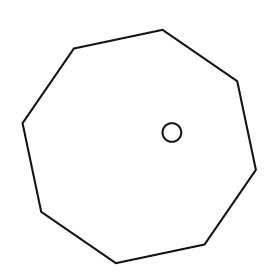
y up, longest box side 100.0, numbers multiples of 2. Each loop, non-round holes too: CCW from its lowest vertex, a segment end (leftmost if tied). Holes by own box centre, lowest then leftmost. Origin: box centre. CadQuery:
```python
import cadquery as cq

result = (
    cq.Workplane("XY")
    .moveTo(-10.0, -50.0)
    .lineTo(28.0, -42.0)
    .lineTo(50.0, -10.0)
    .lineTo(42.0, 28.0)
    .lineTo(10.0, 50.0)
    .lineTo(-28.0, 42.0)
    .lineTo(-50.0, 10.0)
    .lineTo(-42.0, -28.0)
    .close()
    .moveTo(14.0, 6.0)
    .circle(4.0)
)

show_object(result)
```